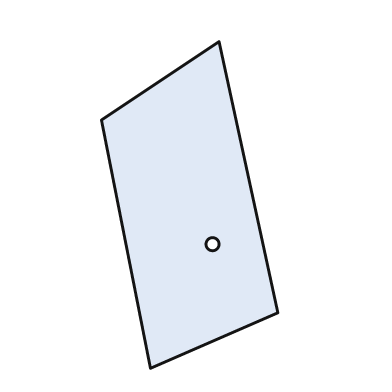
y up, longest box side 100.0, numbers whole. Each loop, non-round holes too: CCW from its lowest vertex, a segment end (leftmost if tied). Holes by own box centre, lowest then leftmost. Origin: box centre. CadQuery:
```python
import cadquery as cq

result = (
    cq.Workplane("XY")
    .moveTo(-12.0, -50.0)
    .lineTo(27.0, -33.0)
    .lineTo(9.0, 50.0)
    .lineTo(-27.0, 26.0)
    .close()
    .moveTo(7.0, -12.0)
    .circle(2.0)
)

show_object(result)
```